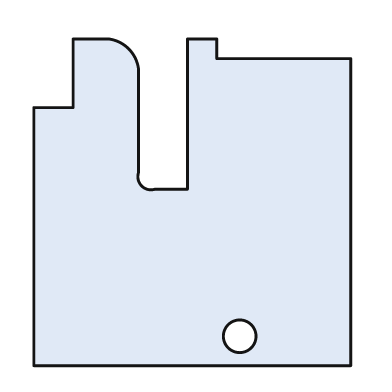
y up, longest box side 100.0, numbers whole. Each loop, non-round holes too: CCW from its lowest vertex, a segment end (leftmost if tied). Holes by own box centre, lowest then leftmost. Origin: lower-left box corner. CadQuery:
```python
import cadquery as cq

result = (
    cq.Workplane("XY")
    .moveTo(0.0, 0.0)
    .lineTo(97.0, 0.0)
    .lineTo(97.0, 94.0)
    .lineTo(56.0, 94.0)
    .lineTo(56.0, 100.0)
    .lineTo(47.0, 100.0)
    .lineTo(47.0, 54.0)
    .lineTo(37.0, 54.0)
    .threePointArc((33.0, 55.0), (32.0, 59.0))
    .lineTo(32.0, 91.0)
    .threePointArc((29.0, 97.0), (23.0, 100.0))
    .lineTo(12.0, 100.0)
    .lineTo(12.0, 79.0)
    .lineTo(0.0, 79.0)
    .close()
    .moveTo(63.0, 9.0)
    .circle(5.0)
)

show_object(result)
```